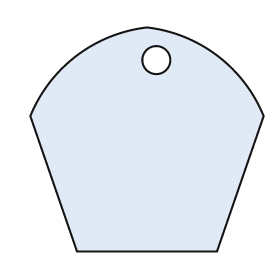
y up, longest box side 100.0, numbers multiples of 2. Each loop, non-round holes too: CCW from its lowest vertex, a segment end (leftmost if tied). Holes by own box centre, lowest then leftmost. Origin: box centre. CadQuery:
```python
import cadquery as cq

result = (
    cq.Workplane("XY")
    .moveTo(-30.0, -48.0)
    .lineTo(30.0, -48.0)
    .lineTo(50.0, 10.0)
    .threePointArc((30.0, 36.0), (0.0, 48.0))
    .threePointArc((-30.0, 36.0), (-50.0, 10.0))
    .close()
    .moveTo(4.0, 34.0)
    .circle(6.0)
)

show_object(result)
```